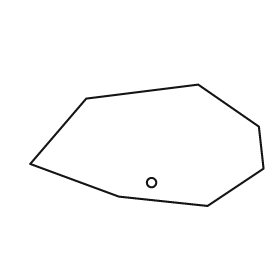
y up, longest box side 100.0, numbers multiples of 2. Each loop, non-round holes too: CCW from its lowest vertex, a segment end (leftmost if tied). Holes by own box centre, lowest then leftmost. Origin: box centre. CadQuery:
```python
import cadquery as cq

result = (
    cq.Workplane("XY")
    .moveTo(26.0, -26.0)
    .lineTo(50.0, -10.0)
    .lineTo(48.0, 8.0)
    .lineTo(22.0, 26.0)
    .lineTo(-26.0, 20.0)
    .lineTo(-50.0, -8.0)
    .lineTo(-12.0, -22.0)
    .close()
    .moveTo(2.0, -16.0)
    .circle(2.0)
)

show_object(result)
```